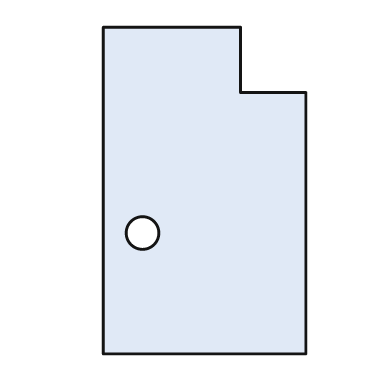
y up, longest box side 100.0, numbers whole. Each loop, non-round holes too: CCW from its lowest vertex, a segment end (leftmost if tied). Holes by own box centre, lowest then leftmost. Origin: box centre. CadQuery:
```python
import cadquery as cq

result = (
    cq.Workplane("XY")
    .moveTo(-31.0, -50.0)
    .lineTo(31.0, -50.0)
    .lineTo(31.0, 30.0)
    .lineTo(11.0, 30.0)
    .lineTo(11.0, 50.0)
    .lineTo(-31.0, 50.0)
    .close()
    .moveTo(-19.0, -13.0)
    .circle(5.0)
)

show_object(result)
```